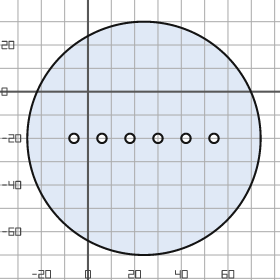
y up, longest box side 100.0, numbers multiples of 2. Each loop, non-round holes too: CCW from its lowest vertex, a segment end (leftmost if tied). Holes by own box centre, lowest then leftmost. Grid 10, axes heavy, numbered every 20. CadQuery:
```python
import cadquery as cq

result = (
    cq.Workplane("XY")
    .moveTo(24.0, -20.0)
    .circle(50.0)
    .moveTo(-6.0, -20.0)
    .circle(2.0)
    .moveTo(6.0, -20.0)
    .circle(2.0)
    .moveTo(18.0, -20.0)
    .circle(2.0)
    .moveTo(30.0, -20.0)
    .circle(2.0)
    .moveTo(42.0, -20.0)
    .circle(2.0)
    .moveTo(54.0, -20.0)
    .circle(2.0)
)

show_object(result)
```